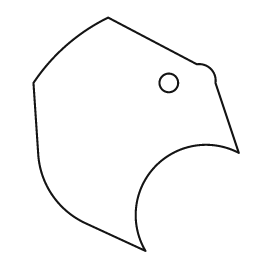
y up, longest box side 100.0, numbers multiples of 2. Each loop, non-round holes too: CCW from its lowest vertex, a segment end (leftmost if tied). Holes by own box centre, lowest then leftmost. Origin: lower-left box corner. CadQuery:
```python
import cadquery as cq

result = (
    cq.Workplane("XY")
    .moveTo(48.0, 0.0)
    .threePointArc((52.0, 36.0), (88.0, 42.0))
    .lineTo(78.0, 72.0)
    .threePointArc((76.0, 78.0), (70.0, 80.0))
    .lineTo(32.0, 100.0)
    .threePointArc((14.0, 88.0), (0.0, 72.0))
    .lineTo(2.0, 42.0)
    .threePointArc((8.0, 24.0), (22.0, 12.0))
    .close()
    .moveTo(58.0, 72.0)
    .circle(4.0)
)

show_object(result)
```